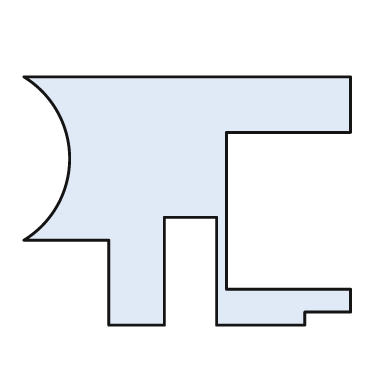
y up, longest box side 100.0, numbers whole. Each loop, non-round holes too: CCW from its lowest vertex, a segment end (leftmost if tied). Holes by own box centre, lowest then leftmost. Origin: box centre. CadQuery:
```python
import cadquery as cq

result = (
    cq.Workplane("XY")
    .moveTo(-24.0, -38.0)
    .lineTo(-7.0, -38.0)
    .lineTo(-7.0, -5.0)
    .lineTo(9.0, -5.0)
    .lineTo(9.0, -38.0)
    .lineTo(36.0, -38.0)
    .lineTo(36.0, -34.0)
    .lineTo(50.0, -34.0)
    .lineTo(50.0, -27.0)
    .lineTo(12.0, -27.0)
    .lineTo(12.0, 21.0)
    .lineTo(50.0, 21.0)
    .lineTo(50.0, 38.0)
    .lineTo(-50.0, 38.0)
    .threePointArc((-36.0, 13.0), (-50.0, -12.0))
    .lineTo(-24.0, -12.0)
    .close()
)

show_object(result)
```